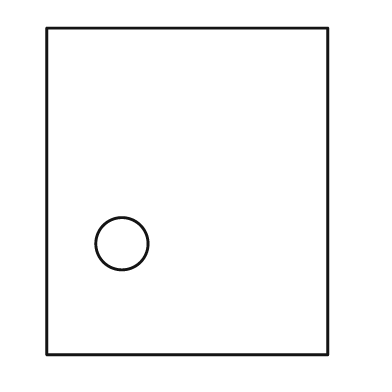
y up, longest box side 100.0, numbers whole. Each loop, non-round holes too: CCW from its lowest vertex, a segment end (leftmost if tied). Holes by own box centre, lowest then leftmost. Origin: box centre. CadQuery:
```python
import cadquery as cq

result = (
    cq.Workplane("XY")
    .moveTo(-43.0, -50.0)
    .lineTo(43.0, -50.0)
    .lineTo(43.0, 50.0)
    .lineTo(-43.0, 50.0)
    .close()
    .moveTo(-20.0, -16.0)
    .circle(8.0)
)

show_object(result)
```